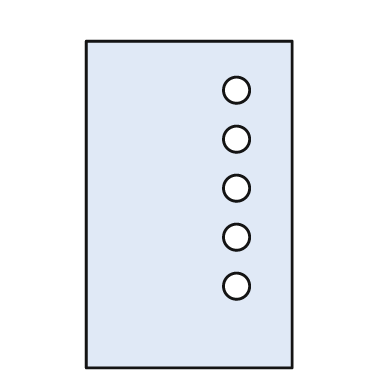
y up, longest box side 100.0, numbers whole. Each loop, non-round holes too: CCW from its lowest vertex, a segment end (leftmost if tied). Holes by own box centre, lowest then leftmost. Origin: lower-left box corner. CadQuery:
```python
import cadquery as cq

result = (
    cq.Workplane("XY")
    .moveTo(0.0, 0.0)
    .lineTo(63.0, 0.0)
    .lineTo(63.0, 100.0)
    .lineTo(0.0, 100.0)
    .close()
    .moveTo(46.0, 25.0)
    .circle(4.0)
    .moveTo(46.0, 40.0)
    .circle(4.0)
    .moveTo(46.0, 55.0)
    .circle(4.0)
    .moveTo(46.0, 70.0)
    .circle(4.0)
    .moveTo(46.0, 85.0)
    .circle(4.0)
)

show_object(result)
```